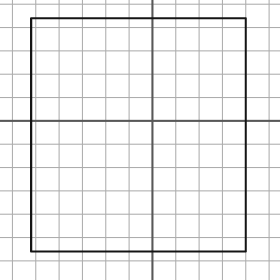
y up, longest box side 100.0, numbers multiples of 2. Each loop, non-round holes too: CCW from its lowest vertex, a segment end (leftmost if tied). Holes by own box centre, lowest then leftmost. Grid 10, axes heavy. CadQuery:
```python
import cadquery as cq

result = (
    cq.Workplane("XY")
    .moveTo(-52.0, -56.0)
    .lineTo(40.0, -56.0)
    .lineTo(40.0, 44.0)
    .lineTo(-52.0, 44.0)
    .close()
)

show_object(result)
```